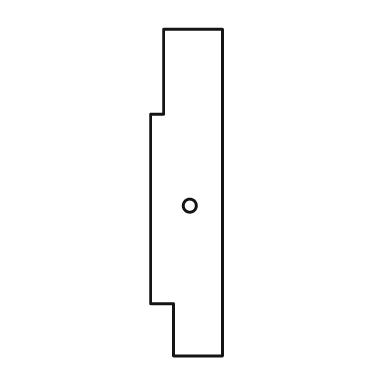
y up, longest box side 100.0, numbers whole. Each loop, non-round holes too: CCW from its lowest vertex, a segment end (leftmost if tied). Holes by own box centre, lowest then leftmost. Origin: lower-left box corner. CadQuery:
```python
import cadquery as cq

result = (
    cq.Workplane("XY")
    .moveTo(7.0, 0.0)
    .lineTo(22.0, 0.0)
    .lineTo(22.0, 100.0)
    .lineTo(4.0, 100.0)
    .lineTo(4.0, 74.0)
    .lineTo(0.0, 74.0)
    .lineTo(0.0, 16.0)
    .lineTo(7.0, 16.0)
    .close()
    .moveTo(12.0, 46.0)
    .circle(2.0)
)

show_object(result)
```